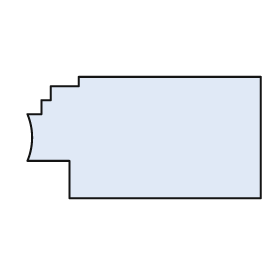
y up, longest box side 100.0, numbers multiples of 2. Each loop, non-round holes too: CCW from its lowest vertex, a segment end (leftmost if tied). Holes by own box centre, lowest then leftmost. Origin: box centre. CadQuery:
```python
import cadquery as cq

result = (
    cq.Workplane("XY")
    .moveTo(-32.0, -26.0)
    .lineTo(50.0, -26.0)
    .lineTo(50.0, 26.0)
    .lineTo(-28.0, 26.0)
    .lineTo(-28.0, 22.0)
    .lineTo(-40.0, 22.0)
    .lineTo(-40.0, 16.0)
    .lineTo(-44.0, 16.0)
    .lineTo(-44.0, 10.0)
    .lineTo(-50.0, 10.0)
    .threePointArc((-48.0, 0.0), (-50.0, -10.0))
    .lineTo(-32.0, -10.0)
    .close()
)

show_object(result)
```